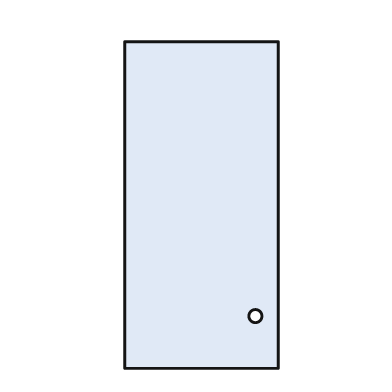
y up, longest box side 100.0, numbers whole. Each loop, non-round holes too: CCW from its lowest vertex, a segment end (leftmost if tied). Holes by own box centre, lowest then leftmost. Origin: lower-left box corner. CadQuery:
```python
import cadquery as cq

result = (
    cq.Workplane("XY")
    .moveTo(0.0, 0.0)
    .lineTo(47.0, 0.0)
    .lineTo(47.0, 100.0)
    .lineTo(0.0, 100.0)
    .close()
    .moveTo(40.0, 16.0)
    .circle(2.0)
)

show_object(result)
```